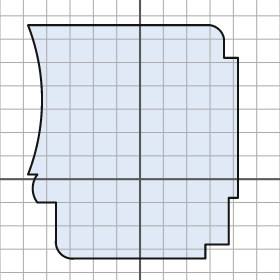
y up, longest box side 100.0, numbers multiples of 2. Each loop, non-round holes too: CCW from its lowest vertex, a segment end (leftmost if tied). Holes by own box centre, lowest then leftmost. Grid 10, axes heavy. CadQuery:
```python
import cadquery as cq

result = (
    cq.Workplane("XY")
    .moveTo(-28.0, -34.0)
    .lineTo(28.0, -34.0)
    .lineTo(28.0, -28.0)
    .lineTo(38.0, -28.0)
    .lineTo(38.0, -8.0)
    .lineTo(42.0, -8.0)
    .lineTo(42.0, 52.0)
    .lineTo(36.0, 52.0)
    .lineTo(36.0, 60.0)
    .threePointArc((34.0, 64.0), (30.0, 66.0))
    .lineTo(-48.0, 66.0)
    .threePointArc((-42.0, 34.0), (-48.0, 2.0))
    .lineTo(-44.0, 2.0)
    .threePointArc((-46.0, -4.0), (-44.0, -10.0))
    .lineTo(-36.0, -10.0)
    .lineTo(-36.0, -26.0)
    .threePointArc((-34.0, -32.0), (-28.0, -34.0))
    .close()
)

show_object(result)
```